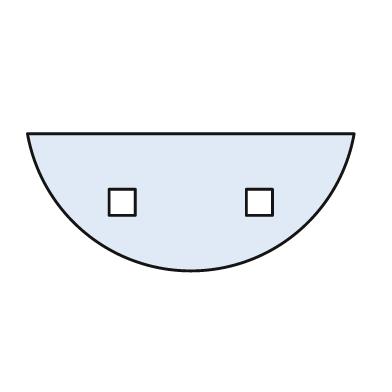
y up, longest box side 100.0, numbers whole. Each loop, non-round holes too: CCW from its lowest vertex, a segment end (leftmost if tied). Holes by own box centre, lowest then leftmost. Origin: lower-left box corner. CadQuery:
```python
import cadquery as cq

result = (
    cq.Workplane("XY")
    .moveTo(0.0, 42.0)
    .threePointArc((50.0, 0.0), (100.0, 42.0))
    .close()
    .moveTo(25.0, 17.0)
    .lineTo(33.0, 17.0)
    .lineTo(33.0, 25.0)
    .lineTo(25.0, 25.0)
    .close()
    .moveTo(67.0, 17.0)
    .lineTo(75.0, 17.0)
    .lineTo(75.0, 25.0)
    .lineTo(67.0, 25.0)
    .close()
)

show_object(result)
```